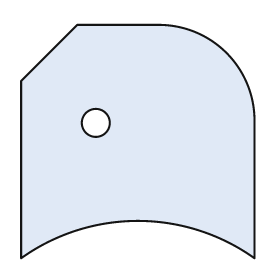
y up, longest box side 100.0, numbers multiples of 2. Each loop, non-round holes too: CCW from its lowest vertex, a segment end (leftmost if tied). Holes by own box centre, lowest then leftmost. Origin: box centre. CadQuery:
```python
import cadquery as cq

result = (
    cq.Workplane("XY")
    .moveTo(-50.0, -50.0)
    .threePointArc((0.0, -34.0), (50.0, -50.0))
    .lineTo(50.0, 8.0)
    .threePointArc((38.0, 38.0), (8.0, 50.0))
    .lineTo(-26.0, 50.0)
    .lineTo(-50.0, 26.0)
    .close()
    .moveTo(-18.0, 8.0)
    .circle(6.0)
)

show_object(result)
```